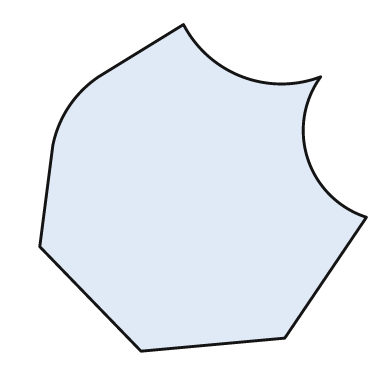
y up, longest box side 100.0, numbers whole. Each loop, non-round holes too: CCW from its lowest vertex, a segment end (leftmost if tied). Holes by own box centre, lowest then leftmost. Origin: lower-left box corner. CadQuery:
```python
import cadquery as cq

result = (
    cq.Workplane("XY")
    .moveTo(31.0, 0.0)
    .lineTo(75.0, 4.0)
    .lineTo(100.0, 41.0)
    .threePointArc((82.0, 59.0), (86.0, 84.0))
    .threePointArc((62.0, 84.0), (44.0, 100.0))
    .lineTo(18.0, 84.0)
    .threePointArc((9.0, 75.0), (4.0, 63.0))
    .lineTo(0.0, 32.0)
    .close()
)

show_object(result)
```